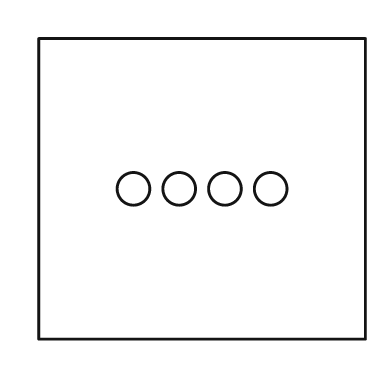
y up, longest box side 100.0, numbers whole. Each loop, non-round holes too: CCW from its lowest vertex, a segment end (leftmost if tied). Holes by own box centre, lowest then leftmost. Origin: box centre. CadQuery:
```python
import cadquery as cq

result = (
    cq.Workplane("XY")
    .moveTo(-50.0, -46.0)
    .lineTo(50.0, -46.0)
    .lineTo(50.0, 46.0)
    .lineTo(-50.0, 46.0)
    .close()
    .moveTo(-21.0, 0.0)
    .circle(5.0)
    .moveTo(-7.0, 0.0)
    .circle(5.0)
    .moveTo(7.0, 0.0)
    .circle(5.0)
    .moveTo(21.0, 0.0)
    .circle(5.0)
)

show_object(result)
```